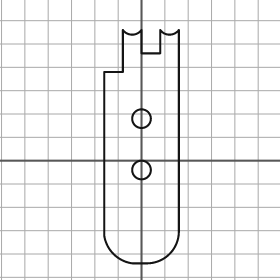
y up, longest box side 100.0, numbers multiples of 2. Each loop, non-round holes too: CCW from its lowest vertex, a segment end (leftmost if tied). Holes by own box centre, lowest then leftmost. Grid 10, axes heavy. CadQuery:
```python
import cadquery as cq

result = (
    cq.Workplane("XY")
    .moveTo(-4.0, -44.0)
    .lineTo(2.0, -44.0)
    .threePointArc((12.0, -40.0), (16.0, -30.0))
    .lineTo(16.0, 56.0)
    .threePointArc((12.0, 54.0), (8.0, 56.0))
    .lineTo(8.0, 46.0)
    .lineTo(0.0, 46.0)
    .lineTo(0.0, 56.0)
    .threePointArc((-4.0, 54.0), (-8.0, 56.0))
    .lineTo(-8.0, 38.0)
    .lineTo(-16.0, 38.0)
    .lineTo(-16.0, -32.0)
    .threePointArc((-12.0, -40.0), (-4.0, -44.0))
    .close()
    .moveTo(0.0, -4.0)
    .circle(4.0)
    .moveTo(0.0, 18.0)
    .circle(4.0)
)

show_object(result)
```